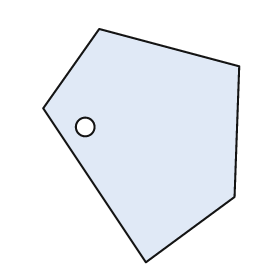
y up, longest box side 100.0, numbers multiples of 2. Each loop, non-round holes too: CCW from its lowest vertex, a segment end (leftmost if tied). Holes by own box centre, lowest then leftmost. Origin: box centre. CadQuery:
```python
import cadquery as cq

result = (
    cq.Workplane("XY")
    .moveTo(2.0, -50.0)
    .lineTo(40.0, -22.0)
    .lineTo(42.0, 34.0)
    .lineTo(-18.0, 50.0)
    .lineTo(-42.0, 16.0)
    .close()
    .moveTo(-24.0, 8.0)
    .circle(4.0)
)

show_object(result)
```